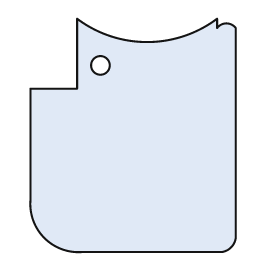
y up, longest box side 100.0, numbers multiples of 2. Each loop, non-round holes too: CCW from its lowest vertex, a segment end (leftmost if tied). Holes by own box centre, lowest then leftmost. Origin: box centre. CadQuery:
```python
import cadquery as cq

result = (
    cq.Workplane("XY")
    .moveTo(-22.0, -50.0)
    .lineTo(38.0, -50.0)
    .threePointArc((42.0, -48.0), (44.0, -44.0))
    .lineTo(44.0, 46.0)
    .threePointArc((40.0, 48.0), (36.0, 46.0))
    .lineTo(36.0, 50.0)
    .threePointArc((6.0, 40.0), (-24.0, 50.0))
    .lineTo(-24.0, 20.0)
    .lineTo(-44.0, 20.0)
    .lineTo(-44.0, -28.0)
    .threePointArc((-38.0, -44.0), (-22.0, -50.0))
    .close()
    .moveTo(-14.0, 30.0)
    .circle(4.0)
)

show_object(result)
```